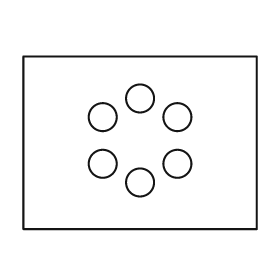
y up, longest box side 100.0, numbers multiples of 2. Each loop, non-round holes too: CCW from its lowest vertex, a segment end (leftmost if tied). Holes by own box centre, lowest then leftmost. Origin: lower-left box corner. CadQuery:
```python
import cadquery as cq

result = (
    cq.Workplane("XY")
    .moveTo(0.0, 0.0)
    .lineTo(100.0, 0.0)
    .lineTo(100.0, 74.0)
    .lineTo(0.0, 74.0)
    .close()
    .moveTo(50.0, 20.0)
    .circle(6.0)
    .moveTo(34.0, 28.0)
    .circle(6.0)
    .moveTo(66.0, 28.0)
    .circle(6.0)
    .moveTo(34.0, 48.0)
    .circle(6.0)
    .moveTo(66.0, 48.0)
    .circle(6.0)
    .moveTo(50.0, 56.0)
    .circle(6.0)
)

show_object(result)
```